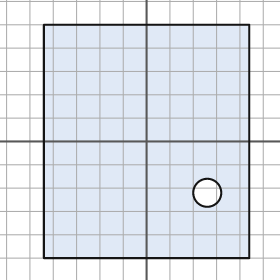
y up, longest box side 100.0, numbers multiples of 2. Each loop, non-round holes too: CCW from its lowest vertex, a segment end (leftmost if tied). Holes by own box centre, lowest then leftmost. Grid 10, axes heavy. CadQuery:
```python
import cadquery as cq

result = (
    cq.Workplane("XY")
    .moveTo(-44.0, -50.0)
    .lineTo(44.0, -50.0)
    .lineTo(44.0, 50.0)
    .lineTo(-44.0, 50.0)
    .close()
    .moveTo(26.0, -22.0)
    .circle(6.0)
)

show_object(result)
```